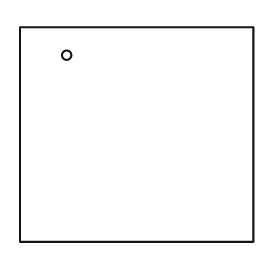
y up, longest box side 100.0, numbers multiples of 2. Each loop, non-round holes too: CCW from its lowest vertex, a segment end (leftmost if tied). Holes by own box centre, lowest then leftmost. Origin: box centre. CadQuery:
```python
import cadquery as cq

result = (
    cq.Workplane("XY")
    .moveTo(-50.0, -46.0)
    .lineTo(50.0, -46.0)
    .lineTo(50.0, 46.0)
    .lineTo(-50.0, 46.0)
    .close()
    .moveTo(-30.0, 34.0)
    .circle(2.0)
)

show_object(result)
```